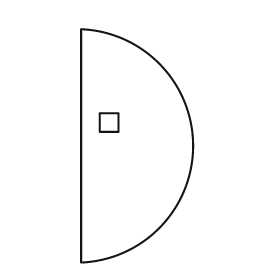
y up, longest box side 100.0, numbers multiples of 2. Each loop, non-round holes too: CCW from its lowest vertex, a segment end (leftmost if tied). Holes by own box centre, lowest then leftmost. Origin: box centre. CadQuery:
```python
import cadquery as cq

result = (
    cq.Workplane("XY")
    .moveTo(-24.0, -50.0)
    .threePointArc((24.0, 0.0), (-24.0, 50.0))
    .close()
    .moveTo(-16.0, 6.0)
    .lineTo(-8.0, 6.0)
    .lineTo(-8.0, 14.0)
    .lineTo(-16.0, 14.0)
    .close()
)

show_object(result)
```